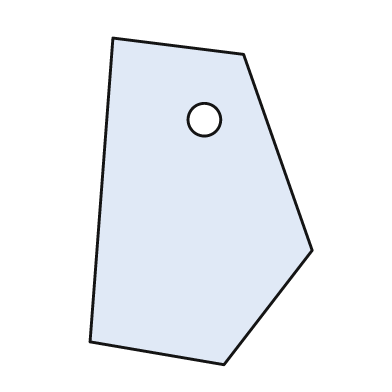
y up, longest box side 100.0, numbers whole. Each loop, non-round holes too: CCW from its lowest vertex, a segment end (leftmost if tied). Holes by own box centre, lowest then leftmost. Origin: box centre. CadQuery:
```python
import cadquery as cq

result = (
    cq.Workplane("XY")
    .moveTo(7.0, -50.0)
    .lineTo(34.0, -15.0)
    .lineTo(13.0, 45.0)
    .lineTo(-27.0, 50.0)
    .lineTo(-34.0, -43.0)
    .close()
    .moveTo(1.0, 25.0)
    .circle(5.0)
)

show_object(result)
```